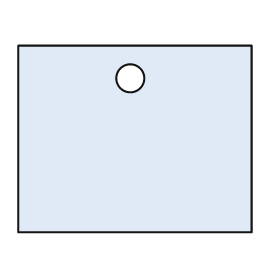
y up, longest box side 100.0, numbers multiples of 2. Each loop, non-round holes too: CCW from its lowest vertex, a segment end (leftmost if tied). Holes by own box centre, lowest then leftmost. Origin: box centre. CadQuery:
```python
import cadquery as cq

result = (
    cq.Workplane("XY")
    .moveTo(-50.0, -40.0)
    .lineTo(50.0, -40.0)
    .lineTo(50.0, 40.0)
    .lineTo(-50.0, 40.0)
    .close()
    .moveTo(-2.0, 26.0)
    .circle(6.0)
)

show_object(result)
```